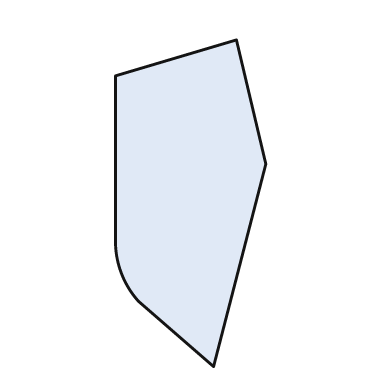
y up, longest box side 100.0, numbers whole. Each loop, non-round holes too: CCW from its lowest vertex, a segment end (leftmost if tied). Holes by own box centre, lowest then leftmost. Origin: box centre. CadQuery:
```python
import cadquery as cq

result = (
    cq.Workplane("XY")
    .moveTo(7.0, -50.0)
    .lineTo(23.0, 12.0)
    .lineTo(14.0, 50.0)
    .lineTo(-23.0, 39.0)
    .lineTo(-23.0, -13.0)
    .threePointArc((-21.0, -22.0), (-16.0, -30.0))
    .close()
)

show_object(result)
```